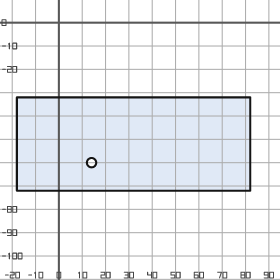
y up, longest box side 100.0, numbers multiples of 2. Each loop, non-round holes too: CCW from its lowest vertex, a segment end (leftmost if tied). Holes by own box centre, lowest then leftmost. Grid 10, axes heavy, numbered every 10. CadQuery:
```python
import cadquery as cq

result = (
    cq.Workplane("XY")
    .moveTo(-18.0, -72.0)
    .lineTo(82.0, -72.0)
    .lineTo(82.0, -32.0)
    .lineTo(-18.0, -32.0)
    .close()
    .moveTo(14.0, -60.0)
    .circle(2.0)
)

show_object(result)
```